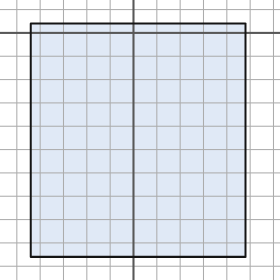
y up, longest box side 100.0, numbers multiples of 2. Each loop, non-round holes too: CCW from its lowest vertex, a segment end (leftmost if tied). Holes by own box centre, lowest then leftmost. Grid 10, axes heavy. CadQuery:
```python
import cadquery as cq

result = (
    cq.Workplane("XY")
    .moveTo(-44.0, -96.0)
    .lineTo(48.0, -96.0)
    .lineTo(48.0, 4.0)
    .lineTo(-44.0, 4.0)
    .close()
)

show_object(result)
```